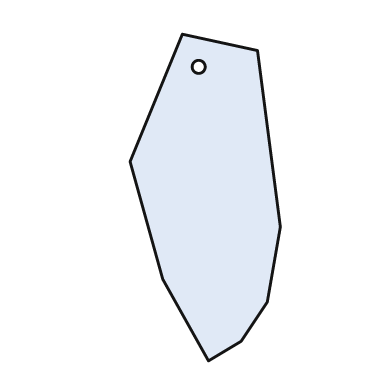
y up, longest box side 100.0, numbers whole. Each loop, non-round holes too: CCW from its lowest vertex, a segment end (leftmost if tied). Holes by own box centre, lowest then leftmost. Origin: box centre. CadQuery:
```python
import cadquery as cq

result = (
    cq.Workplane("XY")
    .moveTo(1.0, -50.0)
    .lineTo(11.0, -44.0)
    .lineTo(19.0, -32.0)
    .lineTo(23.0, -9.0)
    .lineTo(16.0, 45.0)
    .lineTo(-7.0, 50.0)
    .lineTo(-23.0, 11.0)
    .lineTo(-13.0, -25.0)
    .close()
    .moveTo(-2.0, 40.0)
    .circle(2.0)
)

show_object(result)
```